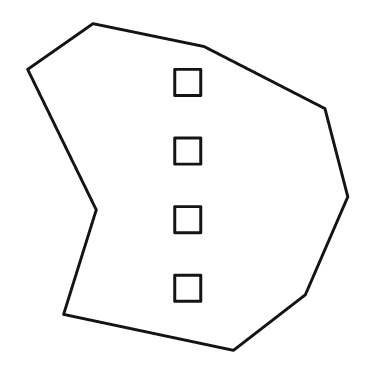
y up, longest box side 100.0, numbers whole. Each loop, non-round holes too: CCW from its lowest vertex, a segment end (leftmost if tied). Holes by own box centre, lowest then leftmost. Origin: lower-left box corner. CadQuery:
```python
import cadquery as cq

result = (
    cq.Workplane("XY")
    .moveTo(63.0, 0.0)
    .lineTo(85.0, 17.0)
    .lineTo(98.0, 47.0)
    .lineTo(91.0, 74.0)
    .lineTo(54.0, 93.0)
    .lineTo(20.0, 100.0)
    .lineTo(0.0, 86.0)
    .lineTo(21.0, 43.0)
    .lineTo(11.0, 11.0)
    .close()
    .moveTo(45.0, 15.0)
    .lineTo(53.0, 15.0)
    .lineTo(53.0, 23.0)
    .lineTo(45.0, 23.0)
    .close()
    .moveTo(45.0, 36.0)
    .lineTo(53.0, 36.0)
    .lineTo(53.0, 44.0)
    .lineTo(45.0, 44.0)
    .close()
    .moveTo(45.0, 57.0)
    .lineTo(53.0, 57.0)
    .lineTo(53.0, 65.0)
    .lineTo(45.0, 65.0)
    .close()
    .moveTo(45.0, 78.0)
    .lineTo(53.0, 78.0)
    .lineTo(53.0, 86.0)
    .lineTo(45.0, 86.0)
    .close()
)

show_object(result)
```